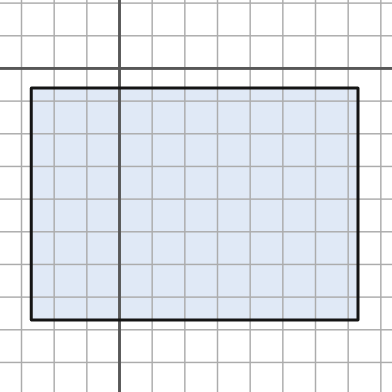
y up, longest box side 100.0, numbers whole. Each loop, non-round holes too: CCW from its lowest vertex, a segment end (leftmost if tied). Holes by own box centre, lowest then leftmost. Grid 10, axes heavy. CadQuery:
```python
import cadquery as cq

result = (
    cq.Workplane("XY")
    .moveTo(-27.0, -77.0)
    .lineTo(73.0, -77.0)
    .lineTo(73.0, -6.0)
    .lineTo(-27.0, -6.0)
    .close()
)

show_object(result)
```